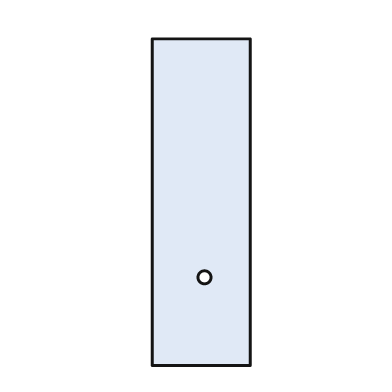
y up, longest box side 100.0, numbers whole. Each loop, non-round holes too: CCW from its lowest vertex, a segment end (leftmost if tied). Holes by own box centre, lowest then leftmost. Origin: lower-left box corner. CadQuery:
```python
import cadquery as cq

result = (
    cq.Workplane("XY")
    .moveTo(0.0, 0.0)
    .lineTo(30.0, 0.0)
    .lineTo(30.0, 100.0)
    .lineTo(0.0, 100.0)
    .close()
    .moveTo(16.0, 27.0)
    .circle(2.0)
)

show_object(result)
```